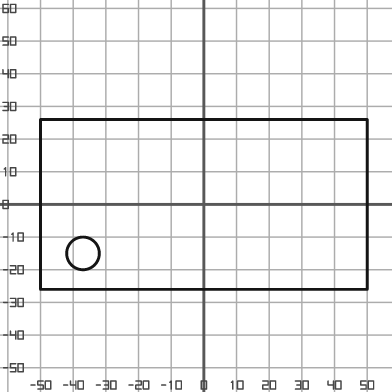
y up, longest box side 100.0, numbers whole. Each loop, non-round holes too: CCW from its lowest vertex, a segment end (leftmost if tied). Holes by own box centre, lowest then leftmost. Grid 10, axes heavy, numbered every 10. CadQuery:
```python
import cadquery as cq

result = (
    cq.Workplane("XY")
    .moveTo(-50.0, -26.0)
    .lineTo(50.0, -26.0)
    .lineTo(50.0, 26.0)
    .lineTo(-50.0, 26.0)
    .close()
    .moveTo(-37.0, -15.0)
    .circle(5.0)
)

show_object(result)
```